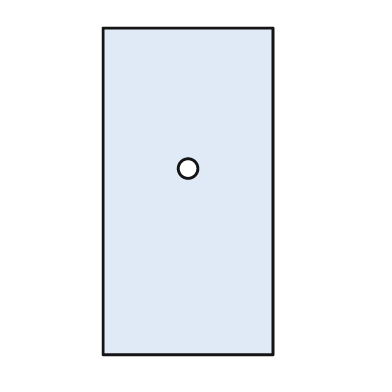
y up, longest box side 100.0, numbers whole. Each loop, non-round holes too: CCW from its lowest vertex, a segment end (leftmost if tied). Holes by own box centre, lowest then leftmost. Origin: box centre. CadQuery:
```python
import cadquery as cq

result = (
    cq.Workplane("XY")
    .moveTo(-26.0, -50.0)
    .lineTo(26.0, -50.0)
    .lineTo(26.0, 50.0)
    .lineTo(-26.0, 50.0)
    .close()
    .moveTo(0.0, 7.0)
    .circle(3.0)
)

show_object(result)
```